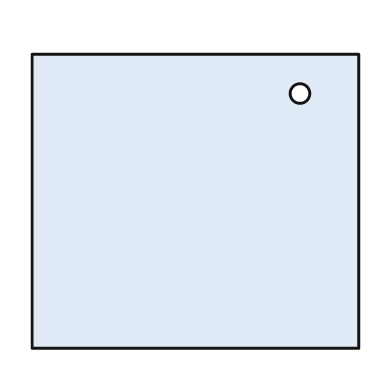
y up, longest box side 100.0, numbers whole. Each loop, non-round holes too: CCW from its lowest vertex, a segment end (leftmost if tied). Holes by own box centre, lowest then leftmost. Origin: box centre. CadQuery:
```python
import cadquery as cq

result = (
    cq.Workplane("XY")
    .moveTo(-50.0, -45.0)
    .lineTo(50.0, -45.0)
    .lineTo(50.0, 45.0)
    .lineTo(-50.0, 45.0)
    .close()
    .moveTo(32.0, 33.0)
    .circle(3.0)
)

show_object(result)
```